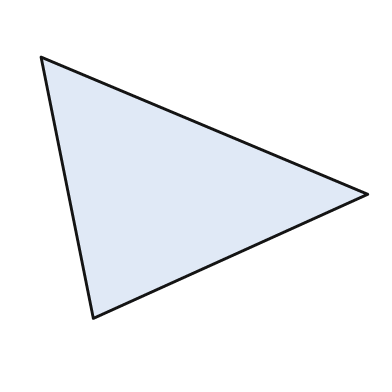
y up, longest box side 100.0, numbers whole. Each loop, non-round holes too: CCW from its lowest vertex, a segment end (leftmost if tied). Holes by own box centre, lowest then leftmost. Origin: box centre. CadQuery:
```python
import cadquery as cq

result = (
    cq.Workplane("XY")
    .moveTo(-34.0, -40.0)
    .lineTo(50.0, -2.0)
    .lineTo(-50.0, 40.0)
    .close()
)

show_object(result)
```